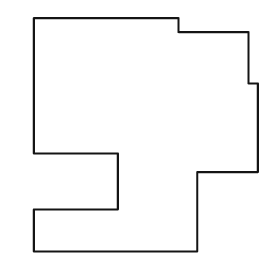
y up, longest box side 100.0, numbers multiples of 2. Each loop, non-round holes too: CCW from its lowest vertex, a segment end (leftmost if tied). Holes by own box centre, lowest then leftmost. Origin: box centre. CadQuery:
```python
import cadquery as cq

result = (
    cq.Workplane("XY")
    .moveTo(-48.0, -50.0)
    .lineTo(22.0, -50.0)
    .lineTo(22.0, -16.0)
    .lineTo(48.0, -16.0)
    .lineTo(48.0, 22.0)
    .lineTo(44.0, 22.0)
    .lineTo(44.0, 44.0)
    .lineTo(14.0, 44.0)
    .lineTo(14.0, 50.0)
    .lineTo(-48.0, 50.0)
    .lineTo(-48.0, -8.0)
    .lineTo(-12.0, -8.0)
    .lineTo(-12.0, -32.0)
    .lineTo(-48.0, -32.0)
    .close()
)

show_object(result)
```